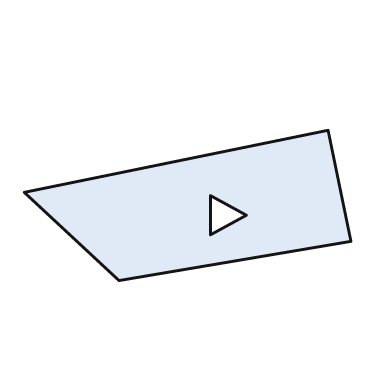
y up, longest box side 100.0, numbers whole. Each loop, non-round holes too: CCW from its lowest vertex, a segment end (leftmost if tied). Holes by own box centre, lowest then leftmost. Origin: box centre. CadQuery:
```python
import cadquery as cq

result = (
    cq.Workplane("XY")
    .moveTo(-21.0, -23.0)
    .lineTo(50.0, -11.0)
    .lineTo(43.0, 23.0)
    .lineTo(-50.0, 4.0)
    .close()
    .moveTo(7.0, -9.0)
    .lineTo(18.0, -3.0)
    .lineTo(7.0, 3.0)
    .close()
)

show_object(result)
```